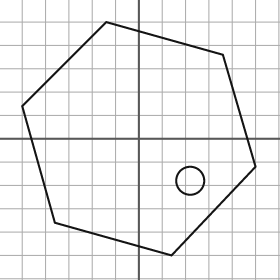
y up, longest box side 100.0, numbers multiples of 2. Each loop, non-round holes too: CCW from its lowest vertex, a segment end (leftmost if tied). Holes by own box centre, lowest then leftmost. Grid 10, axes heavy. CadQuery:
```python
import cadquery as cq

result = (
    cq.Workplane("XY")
    .moveTo(14.0, -50.0)
    .lineTo(50.0, -12.0)
    .lineTo(36.0, 36.0)
    .lineTo(-14.0, 50.0)
    .lineTo(-50.0, 14.0)
    .lineTo(-36.0, -36.0)
    .close()
    .moveTo(22.0, -18.0)
    .circle(6.0)
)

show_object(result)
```